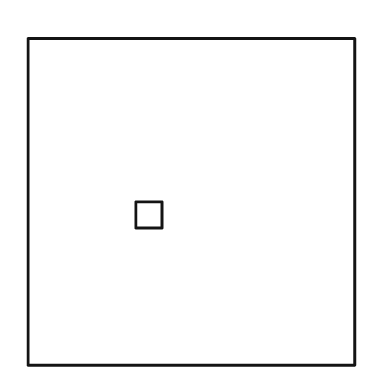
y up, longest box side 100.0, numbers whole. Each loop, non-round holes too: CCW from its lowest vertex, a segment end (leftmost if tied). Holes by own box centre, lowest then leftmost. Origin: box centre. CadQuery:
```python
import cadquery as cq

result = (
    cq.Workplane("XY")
    .moveTo(-50.0, -50.0)
    .lineTo(50.0, -50.0)
    .lineTo(50.0, 50.0)
    .lineTo(-50.0, 50.0)
    .close()
    .moveTo(-17.0, -8.0)
    .lineTo(-9.0, -8.0)
    .lineTo(-9.0, 0.0)
    .lineTo(-17.0, 0.0)
    .close()
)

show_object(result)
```